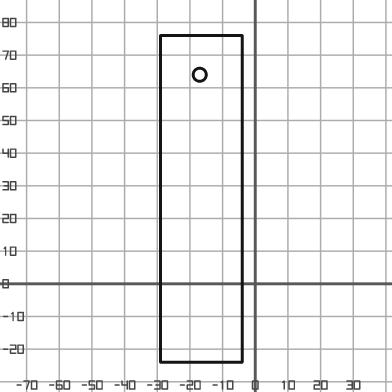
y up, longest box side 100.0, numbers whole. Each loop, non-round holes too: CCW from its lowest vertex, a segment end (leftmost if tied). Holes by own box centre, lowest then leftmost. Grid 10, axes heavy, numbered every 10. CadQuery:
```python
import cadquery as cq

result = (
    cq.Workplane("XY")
    .moveTo(-29.0, -24.0)
    .lineTo(-4.0, -24.0)
    .lineTo(-4.0, 76.0)
    .lineTo(-29.0, 76.0)
    .close()
    .moveTo(-17.0, 64.0)
    .circle(2.0)
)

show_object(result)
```